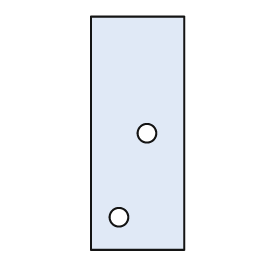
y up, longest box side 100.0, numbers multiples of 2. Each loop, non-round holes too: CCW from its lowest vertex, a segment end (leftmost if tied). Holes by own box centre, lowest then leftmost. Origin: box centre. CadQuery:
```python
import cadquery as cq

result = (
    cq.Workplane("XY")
    .moveTo(-20.0, -50.0)
    .lineTo(20.0, -50.0)
    .lineTo(20.0, 50.0)
    .lineTo(-20.0, 50.0)
    .close()
    .moveTo(-8.0, -36.0)
    .circle(4.0)
    .moveTo(4.0, 0.0)
    .circle(4.0)
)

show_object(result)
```